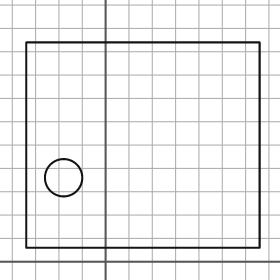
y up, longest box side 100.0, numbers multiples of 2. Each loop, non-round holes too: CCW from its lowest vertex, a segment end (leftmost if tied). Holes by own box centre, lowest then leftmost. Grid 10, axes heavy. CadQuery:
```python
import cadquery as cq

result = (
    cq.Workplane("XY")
    .moveTo(-34.0, 6.0)
    .lineTo(66.0, 6.0)
    .lineTo(66.0, 94.0)
    .lineTo(-34.0, 94.0)
    .close()
    .moveTo(-18.0, 36.0)
    .circle(8.0)
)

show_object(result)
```